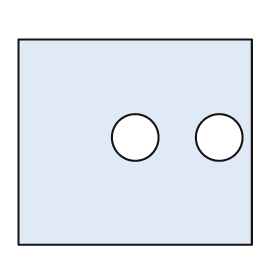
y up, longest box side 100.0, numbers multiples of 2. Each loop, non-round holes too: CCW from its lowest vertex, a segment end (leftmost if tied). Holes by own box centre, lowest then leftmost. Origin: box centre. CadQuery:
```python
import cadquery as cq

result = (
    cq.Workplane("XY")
    .moveTo(-50.0, -44.0)
    .lineTo(50.0, -44.0)
    .lineTo(50.0, 44.0)
    .lineTo(-50.0, 44.0)
    .close()
    .moveTo(0.0, 2.0)
    .circle(10.0)
    .moveTo(36.0, 2.0)
    .circle(10.0)
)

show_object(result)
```